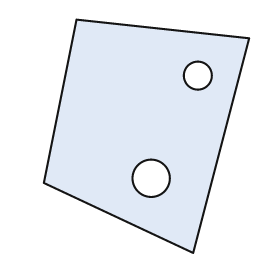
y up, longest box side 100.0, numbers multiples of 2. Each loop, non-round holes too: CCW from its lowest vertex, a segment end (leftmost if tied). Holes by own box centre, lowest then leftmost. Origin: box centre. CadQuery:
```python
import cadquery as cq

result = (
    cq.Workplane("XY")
    .moveTo(20.0, -50.0)
    .lineTo(44.0, 42.0)
    .lineTo(-30.0, 50.0)
    .lineTo(-44.0, -20.0)
    .close()
    .moveTo(2.0, -18.0)
    .circle(8.0)
    .moveTo(22.0, 26.0)
    .circle(6.0)
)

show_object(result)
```